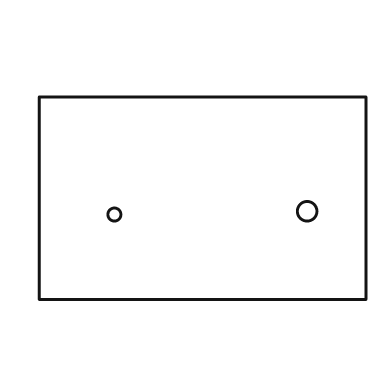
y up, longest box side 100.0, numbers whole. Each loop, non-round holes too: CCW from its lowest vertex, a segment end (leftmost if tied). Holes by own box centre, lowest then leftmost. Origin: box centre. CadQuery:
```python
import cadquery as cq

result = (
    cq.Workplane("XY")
    .moveTo(-50.0, -31.0)
    .lineTo(50.0, -31.0)
    .lineTo(50.0, 31.0)
    .lineTo(-50.0, 31.0)
    .close()
    .moveTo(-27.0, -5.0)
    .circle(2.0)
    .moveTo(32.0, -4.0)
    .circle(3.0)
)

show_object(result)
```